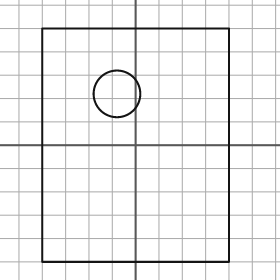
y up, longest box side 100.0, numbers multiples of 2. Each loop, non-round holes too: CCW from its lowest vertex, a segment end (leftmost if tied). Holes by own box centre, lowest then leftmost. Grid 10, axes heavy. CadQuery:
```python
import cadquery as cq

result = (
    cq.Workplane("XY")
    .moveTo(-40.0, -50.0)
    .lineTo(40.0, -50.0)
    .lineTo(40.0, 50.0)
    .lineTo(-40.0, 50.0)
    .close()
    .moveTo(-8.0, 22.0)
    .circle(10.0)
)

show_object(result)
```